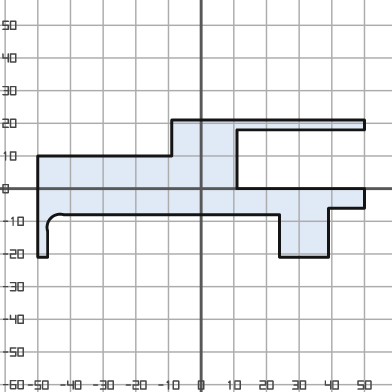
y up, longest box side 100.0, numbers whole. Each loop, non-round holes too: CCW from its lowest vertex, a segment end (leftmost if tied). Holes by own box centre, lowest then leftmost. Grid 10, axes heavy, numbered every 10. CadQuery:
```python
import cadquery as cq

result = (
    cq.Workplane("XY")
    .moveTo(-50.0, -21.0)
    .lineTo(-47.0, -21.0)
    .lineTo(-47.0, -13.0)
    .threePointArc((-46.0, -9.0), (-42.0, -8.0))
    .lineTo(24.0, -8.0)
    .lineTo(24.0, -21.0)
    .lineTo(39.0, -21.0)
    .lineTo(39.0, -6.0)
    .lineTo(50.0, -6.0)
    .lineTo(50.0, 0.0)
    .lineTo(11.0, 0.0)
    .lineTo(11.0, 18.0)
    .lineTo(50.0, 18.0)
    .lineTo(50.0, 21.0)
    .lineTo(-9.0, 21.0)
    .lineTo(-9.0, 10.0)
    .lineTo(-50.0, 10.0)
    .close()
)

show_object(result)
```